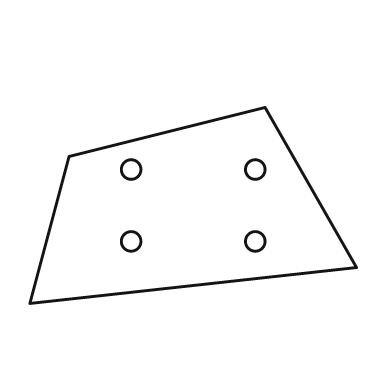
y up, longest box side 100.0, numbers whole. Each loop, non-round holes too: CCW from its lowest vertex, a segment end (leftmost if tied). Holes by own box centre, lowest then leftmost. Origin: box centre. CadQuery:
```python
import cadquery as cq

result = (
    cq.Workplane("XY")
    .moveTo(-50.0, -30.0)
    .lineTo(50.0, -19.0)
    .lineTo(22.0, 30.0)
    .lineTo(-38.0, 15.0)
    .close()
    .moveTo(-19.0, -11.0)
    .circle(3.0)
    .moveTo(19.0, -11.0)
    .circle(3.0)
    .moveTo(-19.0, 11.0)
    .circle(3.0)
    .moveTo(19.0, 11.0)
    .circle(3.0)
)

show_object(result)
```